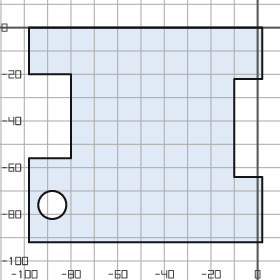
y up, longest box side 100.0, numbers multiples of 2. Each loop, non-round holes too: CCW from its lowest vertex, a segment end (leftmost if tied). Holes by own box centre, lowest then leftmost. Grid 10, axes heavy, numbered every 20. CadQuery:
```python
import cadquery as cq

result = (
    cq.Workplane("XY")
    .moveTo(-98.0, -92.0)
    .lineTo(2.0, -92.0)
    .lineTo(2.0, -64.0)
    .lineTo(-10.0, -64.0)
    .lineTo(-10.0, -22.0)
    .lineTo(2.0, -22.0)
    .lineTo(2.0, 0.0)
    .lineTo(-98.0, 0.0)
    .lineTo(-98.0, -20.0)
    .lineTo(-80.0, -20.0)
    .lineTo(-80.0, -56.0)
    .lineTo(-98.0, -56.0)
    .close()
    .moveTo(-88.0, -76.0)
    .circle(6.0)
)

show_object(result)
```